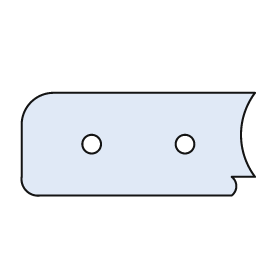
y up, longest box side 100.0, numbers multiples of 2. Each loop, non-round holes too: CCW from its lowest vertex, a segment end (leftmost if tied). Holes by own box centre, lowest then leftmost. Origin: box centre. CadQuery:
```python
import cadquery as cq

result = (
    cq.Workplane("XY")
    .moveTo(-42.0, -22.0)
    .lineTo(40.0, -22.0)
    .threePointArc((42.0, -18.0), (40.0, -14.0))
    .lineTo(50.0, -14.0)
    .threePointArc((44.0, 4.0), (50.0, 22.0))
    .lineTo(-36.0, 22.0)
    .threePointArc((-46.0, 18.0), (-50.0, 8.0))
    .lineTo(-50.0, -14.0)
    .threePointArc((-48.0, -20.0), (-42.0, -22.0))
    .close()
    .moveTo(-20.0, 0.0)
    .circle(4.0)
    .moveTo(20.0, 0.0)
    .circle(4.0)
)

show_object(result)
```